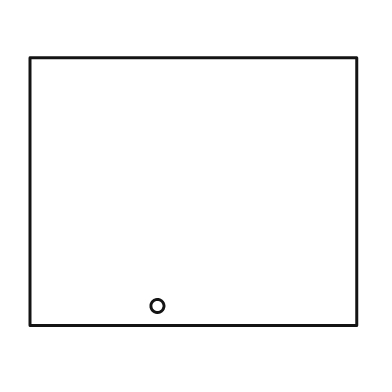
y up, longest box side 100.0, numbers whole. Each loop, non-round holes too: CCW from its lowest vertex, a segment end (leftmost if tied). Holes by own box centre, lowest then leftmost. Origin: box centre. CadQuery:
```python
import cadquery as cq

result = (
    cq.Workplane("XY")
    .moveTo(-50.0, -41.0)
    .lineTo(50.0, -41.0)
    .lineTo(50.0, 41.0)
    .lineTo(-50.0, 41.0)
    .close()
    .moveTo(-11.0, -35.0)
    .circle(2.0)
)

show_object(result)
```